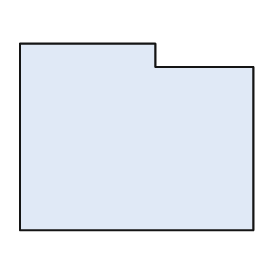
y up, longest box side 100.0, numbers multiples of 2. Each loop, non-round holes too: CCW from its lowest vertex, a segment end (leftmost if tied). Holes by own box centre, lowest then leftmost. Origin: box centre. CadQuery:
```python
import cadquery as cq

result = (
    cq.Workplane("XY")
    .moveTo(-50.0, -40.0)
    .lineTo(50.0, -40.0)
    .lineTo(50.0, 30.0)
    .lineTo(8.0, 30.0)
    .lineTo(8.0, 40.0)
    .lineTo(-50.0, 40.0)
    .close()
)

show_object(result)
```